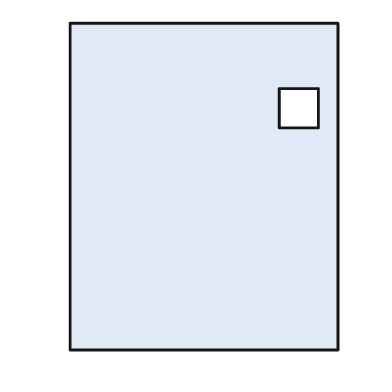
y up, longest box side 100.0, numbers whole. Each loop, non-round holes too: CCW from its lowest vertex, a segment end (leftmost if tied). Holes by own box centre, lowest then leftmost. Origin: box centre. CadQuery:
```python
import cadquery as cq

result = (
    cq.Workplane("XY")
    .moveTo(-41.0, -50.0)
    .lineTo(41.0, -50.0)
    .lineTo(41.0, 50.0)
    .lineTo(-41.0, 50.0)
    .close()
    .moveTo(23.0, 18.0)
    .lineTo(35.0, 18.0)
    .lineTo(35.0, 30.0)
    .lineTo(23.0, 30.0)
    .close()
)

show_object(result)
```